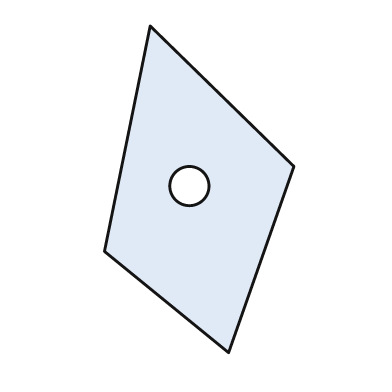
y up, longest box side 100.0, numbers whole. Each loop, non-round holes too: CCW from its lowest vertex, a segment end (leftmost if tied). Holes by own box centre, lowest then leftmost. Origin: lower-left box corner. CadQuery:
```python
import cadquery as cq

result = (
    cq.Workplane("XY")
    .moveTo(38.0, 0.0)
    .lineTo(58.0, 57.0)
    .lineTo(14.0, 100.0)
    .lineTo(0.0, 31.0)
    .close()
    .moveTo(26.0, 51.0)
    .circle(6.0)
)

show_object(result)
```